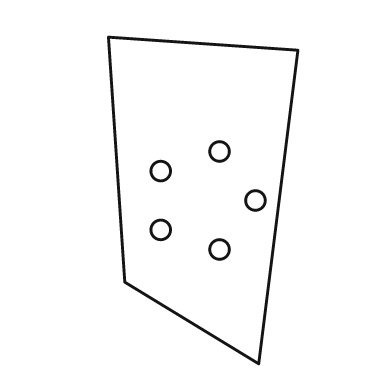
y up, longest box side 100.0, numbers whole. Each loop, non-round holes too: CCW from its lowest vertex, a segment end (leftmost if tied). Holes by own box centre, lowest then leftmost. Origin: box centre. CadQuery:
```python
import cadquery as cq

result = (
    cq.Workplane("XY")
    .moveTo(17.0, -50.0)
    .lineTo(29.0, 46.0)
    .lineTo(-29.0, 50.0)
    .lineTo(-24.0, -25.0)
    .close()
    .moveTo(5.0, -15.0)
    .circle(3.0)
    .moveTo(-13.0, -9.0)
    .circle(3.0)
    .moveTo(16.0, 0.0)
    .circle(3.0)
    .moveTo(-13.0, 9.0)
    .circle(3.0)
    .moveTo(5.0, 15.0)
    .circle(3.0)
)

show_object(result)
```